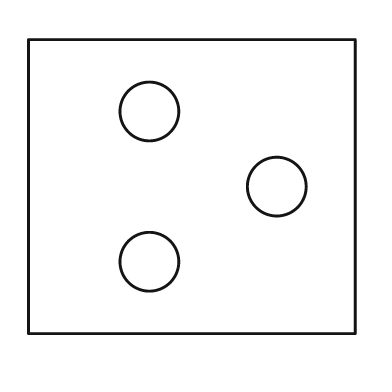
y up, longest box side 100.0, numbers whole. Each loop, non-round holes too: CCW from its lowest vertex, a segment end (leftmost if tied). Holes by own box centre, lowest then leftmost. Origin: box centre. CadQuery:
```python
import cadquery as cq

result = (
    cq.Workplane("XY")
    .moveTo(-50.0, -45.0)
    .lineTo(50.0, -45.0)
    .lineTo(50.0, 45.0)
    .lineTo(-50.0, 45.0)
    .close()
    .moveTo(-13.0, -23.0)
    .circle(9.0)
    .moveTo(26.0, 0.0)
    .circle(9.0)
    .moveTo(-13.0, 23.0)
    .circle(9.0)
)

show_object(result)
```